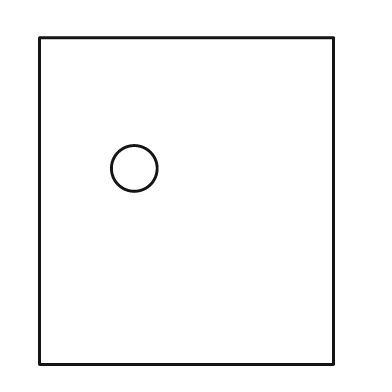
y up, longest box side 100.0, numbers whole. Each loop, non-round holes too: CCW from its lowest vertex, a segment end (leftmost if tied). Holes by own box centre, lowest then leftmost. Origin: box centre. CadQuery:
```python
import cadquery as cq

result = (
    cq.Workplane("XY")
    .moveTo(-45.0, -50.0)
    .lineTo(45.0, -50.0)
    .lineTo(45.0, 50.0)
    .lineTo(-45.0, 50.0)
    .close()
    .moveTo(-16.0, 10.0)
    .circle(7.0)
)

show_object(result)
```